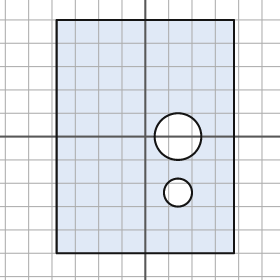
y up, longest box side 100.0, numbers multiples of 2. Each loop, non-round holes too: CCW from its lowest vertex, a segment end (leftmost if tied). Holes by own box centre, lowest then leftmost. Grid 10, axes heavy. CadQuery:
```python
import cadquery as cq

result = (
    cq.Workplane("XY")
    .moveTo(-38.0, -50.0)
    .lineTo(38.0, -50.0)
    .lineTo(38.0, 50.0)
    .lineTo(-38.0, 50.0)
    .close()
    .moveTo(14.0, -24.0)
    .circle(6.0)
    .moveTo(14.0, 0.0)
    .circle(10.0)
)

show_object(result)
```